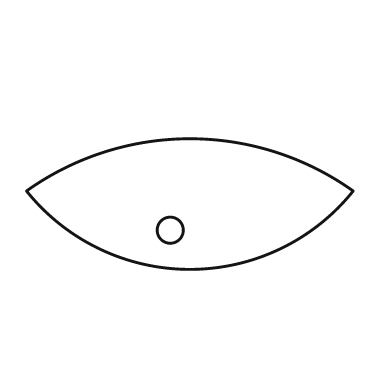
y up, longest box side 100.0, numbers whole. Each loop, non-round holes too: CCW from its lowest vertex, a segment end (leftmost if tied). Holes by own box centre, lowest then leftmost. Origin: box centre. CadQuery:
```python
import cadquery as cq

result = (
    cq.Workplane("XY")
    .moveTo(-50.0, 4.0)
    .threePointArc((0.0, -20.0), (50.0, 4.0))
    .threePointArc((0.0, 20.0), (-50.0, 4.0))
    .close()
    .moveTo(-6.0, -8.0)
    .circle(4.0)
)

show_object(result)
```